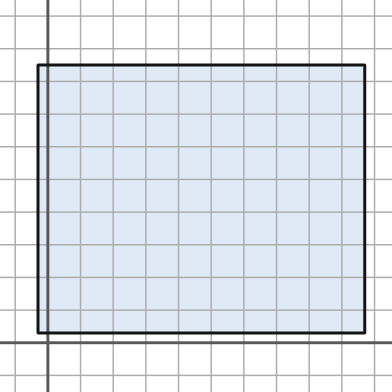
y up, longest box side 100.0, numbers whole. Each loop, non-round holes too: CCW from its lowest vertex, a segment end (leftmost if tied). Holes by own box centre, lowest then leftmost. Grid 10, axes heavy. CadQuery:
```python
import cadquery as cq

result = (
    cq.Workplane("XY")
    .moveTo(-3.0, 3.0)
    .lineTo(97.0, 3.0)
    .lineTo(97.0, 85.0)
    .lineTo(-3.0, 85.0)
    .close()
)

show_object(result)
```